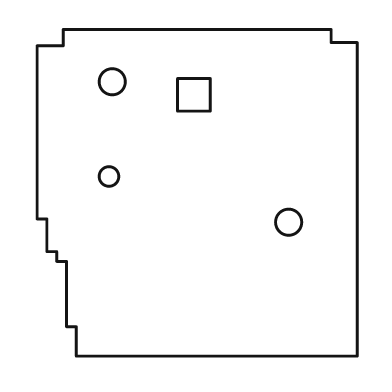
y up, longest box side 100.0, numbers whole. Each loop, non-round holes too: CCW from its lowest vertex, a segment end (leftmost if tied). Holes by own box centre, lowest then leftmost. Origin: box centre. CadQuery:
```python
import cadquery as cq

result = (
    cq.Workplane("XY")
    .moveTo(-37.0, -50.0)
    .lineTo(49.0, -50.0)
    .lineTo(49.0, 46.0)
    .lineTo(41.0, 46.0)
    .lineTo(41.0, 50.0)
    .lineTo(-41.0, 50.0)
    .lineTo(-41.0, 45.0)
    .lineTo(-49.0, 45.0)
    .lineTo(-49.0, -8.0)
    .lineTo(-46.0, -8.0)
    .lineTo(-46.0, -18.0)
    .lineTo(-43.0, -18.0)
    .lineTo(-43.0, -21.0)
    .lineTo(-40.0, -21.0)
    .lineTo(-40.0, -41.0)
    .lineTo(-37.0, -41.0)
    .close()
    .moveTo(28.0, -9.0)
    .circle(4.0)
    .moveTo(-27.0, 5.0)
    .circle(3.0)
    .moveTo(-6.0, 25.0)
    .lineTo(4.0, 25.0)
    .lineTo(4.0, 35.0)
    .lineTo(-6.0, 35.0)
    .close()
    .moveTo(-26.0, 34.0)
    .circle(4.0)
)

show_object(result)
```